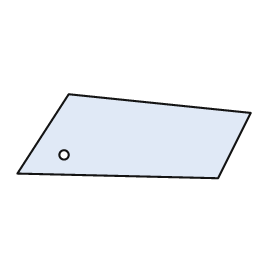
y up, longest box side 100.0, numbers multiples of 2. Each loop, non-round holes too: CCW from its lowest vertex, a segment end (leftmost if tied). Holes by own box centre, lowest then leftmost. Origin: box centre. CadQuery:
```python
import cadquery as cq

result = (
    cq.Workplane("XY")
    .moveTo(36.0, -18.0)
    .lineTo(50.0, 10.0)
    .lineTo(-28.0, 18.0)
    .lineTo(-50.0, -16.0)
    .close()
    .moveTo(-30.0, -8.0)
    .circle(2.0)
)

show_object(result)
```